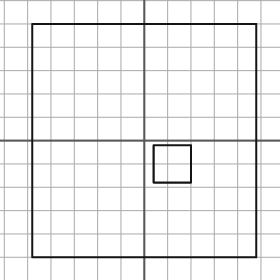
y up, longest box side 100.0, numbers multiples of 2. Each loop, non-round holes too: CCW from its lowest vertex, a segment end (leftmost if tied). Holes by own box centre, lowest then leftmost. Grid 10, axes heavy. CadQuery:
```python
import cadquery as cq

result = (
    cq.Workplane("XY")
    .moveTo(-48.0, -50.0)
    .lineTo(48.0, -50.0)
    .lineTo(48.0, 50.0)
    .lineTo(-48.0, 50.0)
    .close()
    .moveTo(4.0, -18.0)
    .lineTo(20.0, -18.0)
    .lineTo(20.0, -2.0)
    .lineTo(4.0, -2.0)
    .close()
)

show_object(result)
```